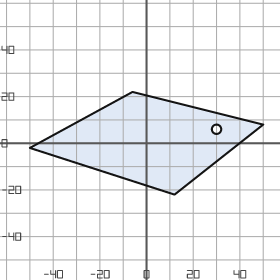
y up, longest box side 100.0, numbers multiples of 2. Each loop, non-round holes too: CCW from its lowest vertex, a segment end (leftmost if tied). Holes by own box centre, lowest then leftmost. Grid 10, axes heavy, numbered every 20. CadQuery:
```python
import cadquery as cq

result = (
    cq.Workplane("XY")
    .moveTo(12.0, -22.0)
    .lineTo(50.0, 8.0)
    .lineTo(-6.0, 22.0)
    .lineTo(-50.0, -2.0)
    .close()
    .moveTo(30.0, 6.0)
    .circle(2.0)
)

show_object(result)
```